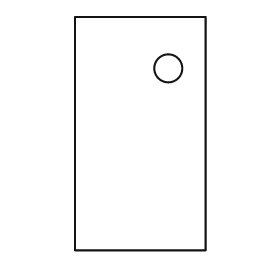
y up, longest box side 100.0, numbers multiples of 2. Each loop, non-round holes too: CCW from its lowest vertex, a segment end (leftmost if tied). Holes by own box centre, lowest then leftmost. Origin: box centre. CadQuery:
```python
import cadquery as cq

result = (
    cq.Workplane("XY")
    .moveTo(-28.0, -50.0)
    .lineTo(28.0, -50.0)
    .lineTo(28.0, 50.0)
    .lineTo(-28.0, 50.0)
    .close()
    .moveTo(12.0, 28.0)
    .circle(6.0)
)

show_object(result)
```